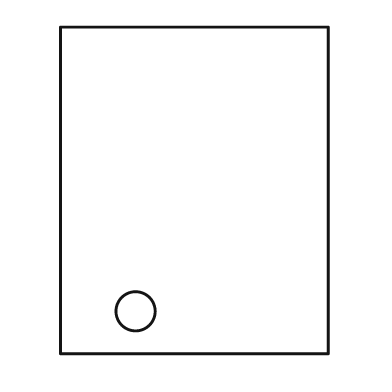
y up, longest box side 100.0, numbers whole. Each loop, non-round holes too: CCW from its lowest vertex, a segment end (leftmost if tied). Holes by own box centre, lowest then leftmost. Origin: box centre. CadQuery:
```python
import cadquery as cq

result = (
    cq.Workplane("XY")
    .moveTo(-41.0, -50.0)
    .lineTo(41.0, -50.0)
    .lineTo(41.0, 50.0)
    .lineTo(-41.0, 50.0)
    .close()
    .moveTo(-18.0, -37.0)
    .circle(6.0)
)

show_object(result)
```